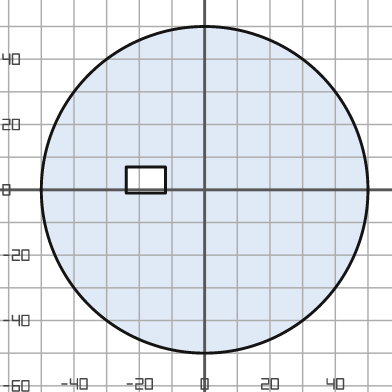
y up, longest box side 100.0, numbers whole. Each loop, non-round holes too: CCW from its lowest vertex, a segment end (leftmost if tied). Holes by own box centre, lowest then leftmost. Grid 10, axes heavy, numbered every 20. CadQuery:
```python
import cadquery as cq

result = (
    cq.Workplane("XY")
    .moveTo(0.0, 0.0)
    .circle(50.0)
    .moveTo(-24.0, -1.0)
    .lineTo(-12.0, -1.0)
    .lineTo(-12.0, 7.0)
    .lineTo(-24.0, 7.0)
    .close()
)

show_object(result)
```